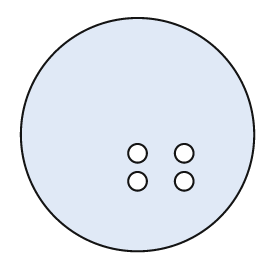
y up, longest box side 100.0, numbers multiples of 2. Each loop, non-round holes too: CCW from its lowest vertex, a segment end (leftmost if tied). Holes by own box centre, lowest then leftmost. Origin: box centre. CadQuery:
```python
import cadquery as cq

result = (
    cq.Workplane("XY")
    .moveTo(0.0, 0.0)
    .circle(50.0)
    .moveTo(0.0, -20.0)
    .circle(4.0)
    .moveTo(20.0, -20.0)
    .circle(4.0)
    .moveTo(0.0, -8.0)
    .circle(4.0)
    .moveTo(20.0, -8.0)
    .circle(4.0)
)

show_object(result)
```